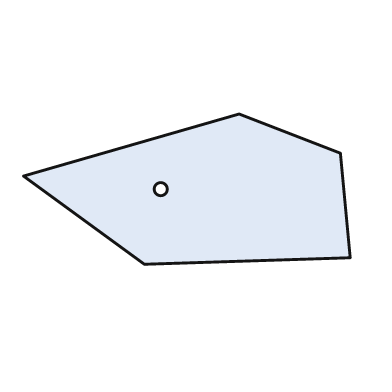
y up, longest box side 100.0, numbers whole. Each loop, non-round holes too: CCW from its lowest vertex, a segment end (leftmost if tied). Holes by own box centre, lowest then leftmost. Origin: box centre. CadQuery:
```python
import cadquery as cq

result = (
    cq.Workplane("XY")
    .moveTo(-13.0, -23.0)
    .lineTo(50.0, -21.0)
    .lineTo(47.0, 11.0)
    .lineTo(16.0, 23.0)
    .lineTo(-50.0, 4.0)
    .close()
    .moveTo(-8.0, 0.0)
    .circle(2.0)
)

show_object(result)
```